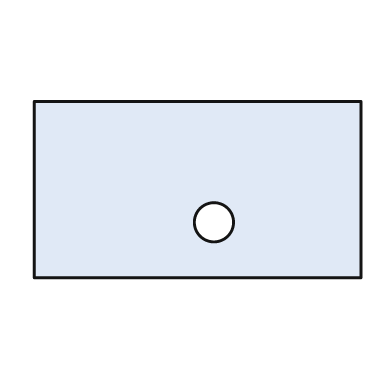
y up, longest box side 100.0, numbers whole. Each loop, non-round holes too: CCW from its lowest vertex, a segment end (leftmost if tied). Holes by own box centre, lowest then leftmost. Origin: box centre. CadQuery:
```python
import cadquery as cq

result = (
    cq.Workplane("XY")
    .moveTo(-50.0, -27.0)
    .lineTo(50.0, -27.0)
    .lineTo(50.0, 27.0)
    .lineTo(-50.0, 27.0)
    .close()
    .moveTo(5.0, -10.0)
    .circle(6.0)
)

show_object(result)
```